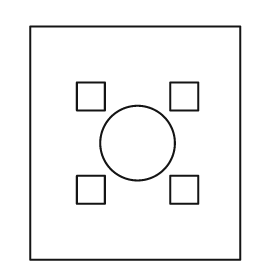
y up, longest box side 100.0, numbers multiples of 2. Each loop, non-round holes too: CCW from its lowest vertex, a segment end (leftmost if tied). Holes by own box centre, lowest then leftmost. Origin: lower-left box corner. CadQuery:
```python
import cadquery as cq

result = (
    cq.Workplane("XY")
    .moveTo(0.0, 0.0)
    .lineTo(90.0, 0.0)
    .lineTo(90.0, 100.0)
    .lineTo(0.0, 100.0)
    .close()
    .moveTo(20.0, 24.0)
    .lineTo(32.0, 24.0)
    .lineTo(32.0, 36.0)
    .lineTo(20.0, 36.0)
    .close()
    .moveTo(60.0, 24.0)
    .lineTo(72.0, 24.0)
    .lineTo(72.0, 36.0)
    .lineTo(60.0, 36.0)
    .close()
    .moveTo(46.0, 50.0)
    .circle(16.0)
    .moveTo(20.0, 64.0)
    .lineTo(32.0, 64.0)
    .lineTo(32.0, 76.0)
    .lineTo(20.0, 76.0)
    .close()
    .moveTo(60.0, 64.0)
    .lineTo(72.0, 64.0)
    .lineTo(72.0, 76.0)
    .lineTo(60.0, 76.0)
    .close()
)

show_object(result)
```